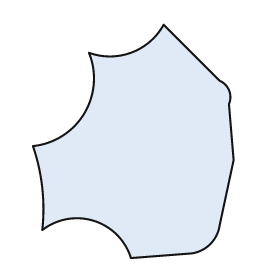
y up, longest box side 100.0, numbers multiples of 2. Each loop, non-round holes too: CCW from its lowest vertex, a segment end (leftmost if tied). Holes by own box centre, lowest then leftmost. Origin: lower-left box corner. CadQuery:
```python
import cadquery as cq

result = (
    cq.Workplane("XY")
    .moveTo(42.0, 0.0)
    .lineTo(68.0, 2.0)
    .threePointArc((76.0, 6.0), (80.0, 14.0))
    .lineTo(86.0, 42.0)
    .lineTo(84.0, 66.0)
    .threePointArc((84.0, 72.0), (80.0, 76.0))
    .lineTo(56.0, 100.0)
    .threePointArc((42.0, 88.0), (24.0, 88.0))
    .threePointArc((22.0, 62.0), (0.0, 48.0))
    .threePointArc((4.0, 30.0), (4.0, 12.0))
    .threePointArc((26.0, 16.0), (42.0, 0.0))
    .close()
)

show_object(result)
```